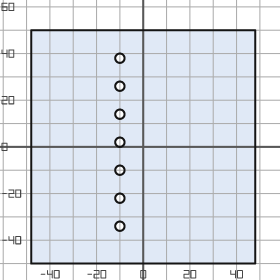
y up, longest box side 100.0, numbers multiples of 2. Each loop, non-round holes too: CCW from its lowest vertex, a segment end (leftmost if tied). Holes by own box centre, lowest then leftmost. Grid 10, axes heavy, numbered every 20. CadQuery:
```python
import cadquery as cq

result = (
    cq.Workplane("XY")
    .moveTo(-48.0, -50.0)
    .lineTo(48.0, -50.0)
    .lineTo(48.0, 50.0)
    .lineTo(-48.0, 50.0)
    .close()
    .moveTo(-10.0, -34.0)
    .circle(2.0)
    .moveTo(-10.0, -22.0)
    .circle(2.0)
    .moveTo(-10.0, -10.0)
    .circle(2.0)
    .moveTo(-10.0, 2.0)
    .circle(2.0)
    .moveTo(-10.0, 14.0)
    .circle(2.0)
    .moveTo(-10.0, 26.0)
    .circle(2.0)
    .moveTo(-10.0, 38.0)
    .circle(2.0)
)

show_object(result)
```